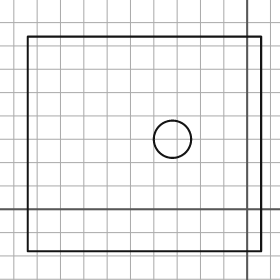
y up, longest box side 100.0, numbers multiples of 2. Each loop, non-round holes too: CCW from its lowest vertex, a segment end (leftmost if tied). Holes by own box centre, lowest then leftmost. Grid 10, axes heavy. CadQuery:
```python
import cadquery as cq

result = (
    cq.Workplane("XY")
    .moveTo(-94.0, -18.0)
    .lineTo(6.0, -18.0)
    .lineTo(6.0, 74.0)
    .lineTo(-94.0, 74.0)
    .close()
    .moveTo(-32.0, 30.0)
    .circle(8.0)
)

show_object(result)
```